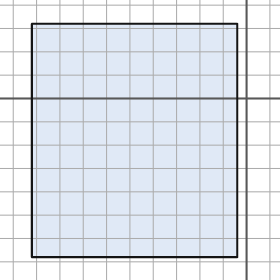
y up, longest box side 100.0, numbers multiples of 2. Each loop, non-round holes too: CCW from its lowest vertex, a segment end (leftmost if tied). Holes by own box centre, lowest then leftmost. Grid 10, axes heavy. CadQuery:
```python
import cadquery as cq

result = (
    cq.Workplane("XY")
    .moveTo(-92.0, -68.0)
    .lineTo(-4.0, -68.0)
    .lineTo(-4.0, 32.0)
    .lineTo(-92.0, 32.0)
    .close()
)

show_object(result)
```